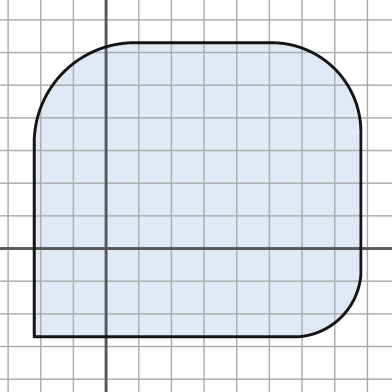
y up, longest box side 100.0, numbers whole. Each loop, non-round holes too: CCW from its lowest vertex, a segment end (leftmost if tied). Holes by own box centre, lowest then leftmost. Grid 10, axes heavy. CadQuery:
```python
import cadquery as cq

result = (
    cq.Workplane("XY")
    .moveTo(-22.0, -27.0)
    .lineTo(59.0, -27.0)
    .threePointArc((72.0, -21.0), (78.0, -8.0))
    .lineTo(78.0, 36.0)
    .threePointArc((70.0, 55.0), (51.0, 63.0))
    .lineTo(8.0, 63.0)
    .threePointArc((-13.0, 54.0), (-22.0, 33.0))
    .close()
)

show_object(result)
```